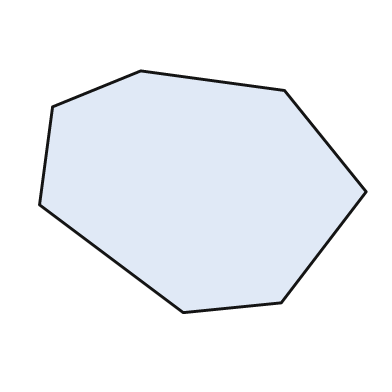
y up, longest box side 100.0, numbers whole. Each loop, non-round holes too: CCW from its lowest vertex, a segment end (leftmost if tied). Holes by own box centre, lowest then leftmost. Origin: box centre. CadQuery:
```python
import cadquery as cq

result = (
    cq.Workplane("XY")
    .moveTo(-6.0, -37.0)
    .lineTo(24.0, -34.0)
    .lineTo(50.0, 0.0)
    .lineTo(25.0, 31.0)
    .lineTo(-19.0, 37.0)
    .lineTo(-46.0, 26.0)
    .lineTo(-50.0, -4.0)
    .close()
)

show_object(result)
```